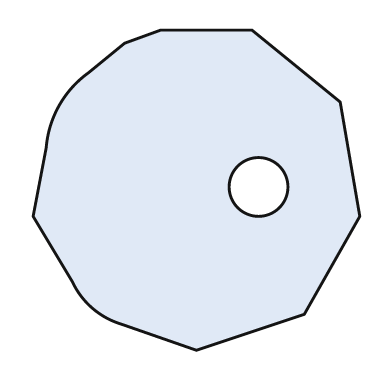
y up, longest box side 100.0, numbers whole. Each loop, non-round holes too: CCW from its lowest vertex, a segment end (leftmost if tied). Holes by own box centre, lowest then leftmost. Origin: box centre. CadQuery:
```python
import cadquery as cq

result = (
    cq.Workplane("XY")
    .moveTo(0.0, -49.0)
    .lineTo(33.0, -38.0)
    .lineTo(50.0, -8.0)
    .lineTo(44.0, 27.0)
    .lineTo(17.0, 49.0)
    .lineTo(-11.0, 49.0)
    .lineTo(-22.0, 45.0)
    .lineTo(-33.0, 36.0)
    .threePointArc((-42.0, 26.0), (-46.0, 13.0))
    .lineTo(-50.0, -8.0)
    .lineTo(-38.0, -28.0)
    .threePointArc((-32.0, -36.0), (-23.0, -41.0))
    .close()
    .moveTo(19.0, 1.0)
    .circle(9.0)
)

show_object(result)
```